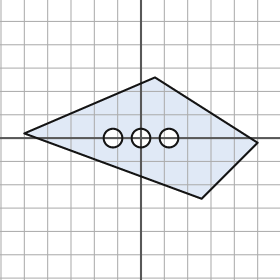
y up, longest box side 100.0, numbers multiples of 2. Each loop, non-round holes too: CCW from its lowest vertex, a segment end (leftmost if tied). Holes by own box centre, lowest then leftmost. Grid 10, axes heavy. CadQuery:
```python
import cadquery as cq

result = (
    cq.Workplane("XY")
    .moveTo(26.0, -26.0)
    .lineTo(50.0, -2.0)
    .lineTo(6.0, 26.0)
    .lineTo(-50.0, 2.0)
    .close()
    .moveTo(-12.0, 0.0)
    .circle(4.0)
    .moveTo(0.0, 0.0)
    .circle(4.0)
    .moveTo(12.0, 0.0)
    .circle(4.0)
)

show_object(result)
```